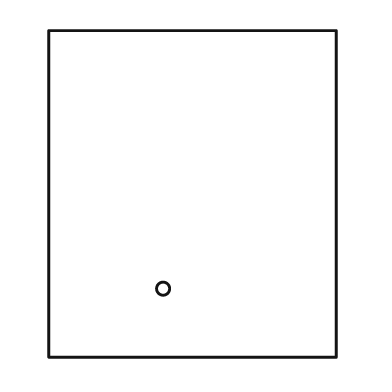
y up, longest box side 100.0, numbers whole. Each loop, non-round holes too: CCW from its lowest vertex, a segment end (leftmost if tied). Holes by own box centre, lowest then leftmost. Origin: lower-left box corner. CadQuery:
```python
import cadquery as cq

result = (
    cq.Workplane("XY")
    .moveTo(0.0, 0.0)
    .lineTo(88.0, 0.0)
    .lineTo(88.0, 100.0)
    .lineTo(0.0, 100.0)
    .close()
    .moveTo(35.0, 21.0)
    .circle(2.0)
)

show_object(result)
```